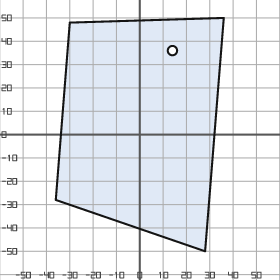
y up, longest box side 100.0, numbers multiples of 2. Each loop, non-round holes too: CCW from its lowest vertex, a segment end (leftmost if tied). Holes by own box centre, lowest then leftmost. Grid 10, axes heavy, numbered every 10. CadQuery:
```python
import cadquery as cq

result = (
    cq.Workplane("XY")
    .moveTo(28.0, -50.0)
    .lineTo(36.0, 50.0)
    .lineTo(-30.0, 48.0)
    .lineTo(-36.0, -28.0)
    .close()
    .moveTo(14.0, 36.0)
    .circle(2.0)
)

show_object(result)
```